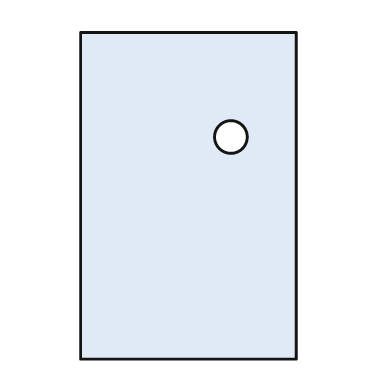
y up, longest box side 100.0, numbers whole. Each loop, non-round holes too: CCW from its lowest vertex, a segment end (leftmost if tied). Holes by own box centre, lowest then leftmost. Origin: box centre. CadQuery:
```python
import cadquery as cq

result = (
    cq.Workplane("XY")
    .moveTo(-33.0, -50.0)
    .lineTo(33.0, -50.0)
    .lineTo(33.0, 50.0)
    .lineTo(-33.0, 50.0)
    .close()
    .moveTo(13.0, 18.0)
    .circle(5.0)
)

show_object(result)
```